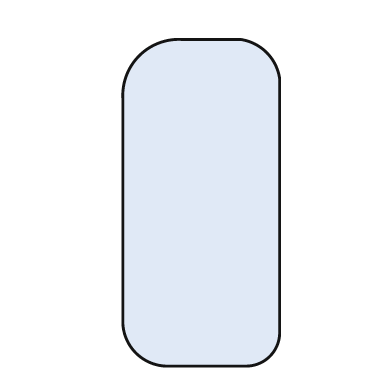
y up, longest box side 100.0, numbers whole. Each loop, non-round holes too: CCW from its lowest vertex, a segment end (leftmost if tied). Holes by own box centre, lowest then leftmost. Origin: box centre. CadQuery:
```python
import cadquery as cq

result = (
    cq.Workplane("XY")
    .moveTo(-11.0, -50.0)
    .lineTo(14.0, -50.0)
    .threePointArc((21.0, -47.0), (24.0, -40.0))
    .lineTo(24.0, 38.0)
    .threePointArc((20.0, 46.0), (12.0, 50.0))
    .lineTo(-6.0, 50.0)
    .threePointArc((-19.0, 45.0), (-24.0, 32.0))
    .lineTo(-24.0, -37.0)
    .threePointArc((-20.0, -46.0), (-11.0, -50.0))
    .close()
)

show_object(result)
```